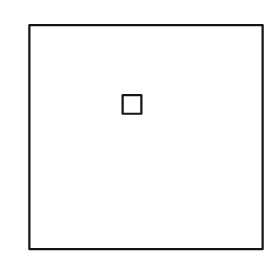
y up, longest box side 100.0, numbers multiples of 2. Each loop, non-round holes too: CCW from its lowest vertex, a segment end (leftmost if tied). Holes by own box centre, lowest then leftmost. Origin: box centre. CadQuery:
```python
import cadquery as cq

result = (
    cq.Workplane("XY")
    .moveTo(-50.0, -48.0)
    .lineTo(50.0, -48.0)
    .lineTo(50.0, 48.0)
    .lineTo(-50.0, 48.0)
    .close()
    .moveTo(-10.0, 10.0)
    .lineTo(-2.0, 10.0)
    .lineTo(-2.0, 18.0)
    .lineTo(-10.0, 18.0)
    .close()
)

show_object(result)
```